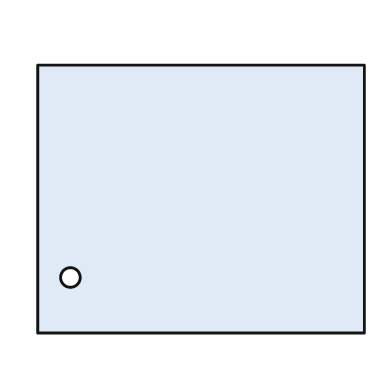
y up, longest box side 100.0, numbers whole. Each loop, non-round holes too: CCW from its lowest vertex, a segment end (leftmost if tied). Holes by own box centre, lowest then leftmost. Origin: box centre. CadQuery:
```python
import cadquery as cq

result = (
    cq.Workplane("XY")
    .moveTo(-50.0, -41.0)
    .lineTo(50.0, -41.0)
    .lineTo(50.0, 41.0)
    .lineTo(-50.0, 41.0)
    .close()
    .moveTo(-40.0, -24.0)
    .circle(3.0)
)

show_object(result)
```